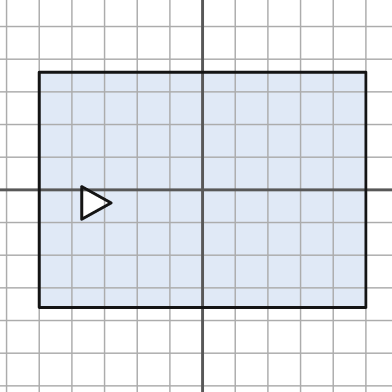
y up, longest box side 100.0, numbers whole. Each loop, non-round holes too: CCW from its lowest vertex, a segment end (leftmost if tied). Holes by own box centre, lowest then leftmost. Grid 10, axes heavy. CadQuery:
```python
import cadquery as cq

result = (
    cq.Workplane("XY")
    .moveTo(-50.0, -36.0)
    .lineTo(50.0, -36.0)
    .lineTo(50.0, 36.0)
    .lineTo(-50.0, 36.0)
    .close()
    .moveTo(-37.0, -9.0)
    .lineTo(-28.0, -4.0)
    .lineTo(-37.0, 1.0)
    .close()
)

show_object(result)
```